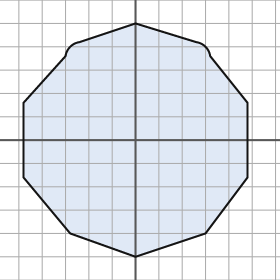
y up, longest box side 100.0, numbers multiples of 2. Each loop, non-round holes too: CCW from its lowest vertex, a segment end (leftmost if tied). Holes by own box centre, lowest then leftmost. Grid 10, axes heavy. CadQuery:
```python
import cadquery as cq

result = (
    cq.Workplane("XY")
    .moveTo(0.0, -50.0)
    .lineTo(30.0, -40.0)
    .lineTo(48.0, -16.0)
    .lineTo(48.0, 16.0)
    .lineTo(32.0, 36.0)
    .threePointArc((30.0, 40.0), (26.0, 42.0))
    .lineTo(0.0, 50.0)
    .lineTo(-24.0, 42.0)
    .threePointArc((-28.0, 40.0), (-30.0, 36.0))
    .lineTo(-48.0, 16.0)
    .lineTo(-48.0, -16.0)
    .lineTo(-28.0, -40.0)
    .close()
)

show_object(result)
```